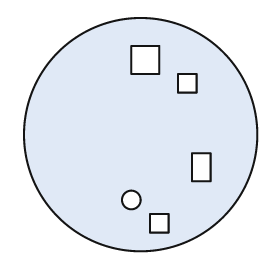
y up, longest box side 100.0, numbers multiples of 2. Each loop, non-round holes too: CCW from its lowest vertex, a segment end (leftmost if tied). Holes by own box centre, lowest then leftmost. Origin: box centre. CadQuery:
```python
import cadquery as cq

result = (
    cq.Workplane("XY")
    .moveTo(0.0, 0.0)
    .circle(50.0)
    .moveTo(4.0, -42.0)
    .lineTo(12.0, -42.0)
    .lineTo(12.0, -34.0)
    .lineTo(4.0, -34.0)
    .close()
    .moveTo(-4.0, -28.0)
    .circle(4.0)
    .moveTo(22.0, -20.0)
    .lineTo(30.0, -20.0)
    .lineTo(30.0, -8.0)
    .lineTo(22.0, -8.0)
    .close()
    .moveTo(16.0, 18.0)
    .lineTo(24.0, 18.0)
    .lineTo(24.0, 26.0)
    .lineTo(16.0, 26.0)
    .close()
    .moveTo(-4.0, 26.0)
    .lineTo(8.0, 26.0)
    .lineTo(8.0, 38.0)
    .lineTo(-4.0, 38.0)
    .close()
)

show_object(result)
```